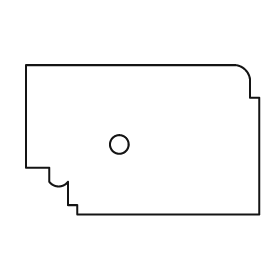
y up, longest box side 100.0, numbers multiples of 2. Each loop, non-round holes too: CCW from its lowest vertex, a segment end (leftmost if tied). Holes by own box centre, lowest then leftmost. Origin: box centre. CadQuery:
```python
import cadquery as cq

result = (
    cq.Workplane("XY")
    .moveTo(-28.0, -32.0)
    .lineTo(50.0, -32.0)
    .lineTo(50.0, 18.0)
    .lineTo(46.0, 18.0)
    .lineTo(46.0, 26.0)
    .threePointArc((44.0, 30.0), (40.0, 32.0))
    .lineTo(-50.0, 32.0)
    .lineTo(-50.0, -12.0)
    .lineTo(-40.0, -12.0)
    .lineTo(-40.0, -18.0)
    .threePointArc((-36.0, -20.0), (-32.0, -18.0))
    .lineTo(-32.0, -28.0)
    .lineTo(-28.0, -28.0)
    .close()
    .moveTo(-10.0, -2.0)
    .circle(4.0)
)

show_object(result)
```